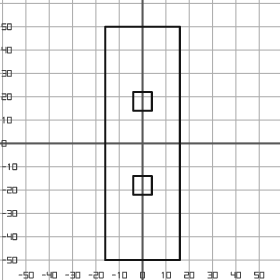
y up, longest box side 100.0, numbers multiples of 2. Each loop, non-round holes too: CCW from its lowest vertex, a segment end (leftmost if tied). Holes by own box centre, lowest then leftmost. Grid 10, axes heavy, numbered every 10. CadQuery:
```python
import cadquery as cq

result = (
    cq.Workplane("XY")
    .moveTo(-16.0, -50.0)
    .lineTo(16.0, -50.0)
    .lineTo(16.0, 50.0)
    .lineTo(-16.0, 50.0)
    .close()
    .moveTo(-4.0, -22.0)
    .lineTo(4.0, -22.0)
    .lineTo(4.0, -14.0)
    .lineTo(-4.0, -14.0)
    .close()
    .moveTo(-4.0, 14.0)
    .lineTo(4.0, 14.0)
    .lineTo(4.0, 22.0)
    .lineTo(-4.0, 22.0)
    .close()
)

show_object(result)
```